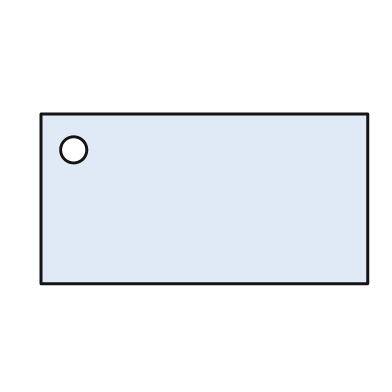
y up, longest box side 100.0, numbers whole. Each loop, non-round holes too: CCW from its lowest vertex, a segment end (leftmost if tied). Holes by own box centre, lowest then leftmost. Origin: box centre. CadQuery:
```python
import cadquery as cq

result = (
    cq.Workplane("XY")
    .moveTo(-50.0, -26.0)
    .lineTo(50.0, -26.0)
    .lineTo(50.0, 26.0)
    .lineTo(-50.0, 26.0)
    .close()
    .moveTo(-40.0, 15.0)
    .circle(4.0)
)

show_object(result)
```